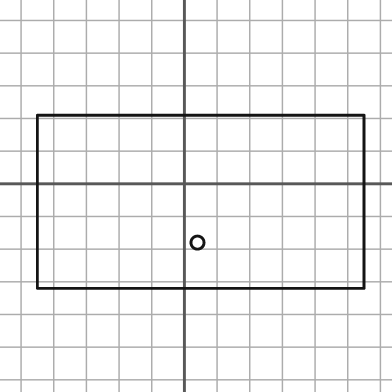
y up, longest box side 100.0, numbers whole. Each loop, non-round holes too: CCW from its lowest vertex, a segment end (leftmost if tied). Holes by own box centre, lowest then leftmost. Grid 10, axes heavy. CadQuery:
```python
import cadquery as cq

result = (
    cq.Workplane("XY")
    .moveTo(-45.0, -32.0)
    .lineTo(55.0, -32.0)
    .lineTo(55.0, 21.0)
    .lineTo(-45.0, 21.0)
    .close()
    .moveTo(4.0, -18.0)
    .circle(2.0)
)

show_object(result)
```